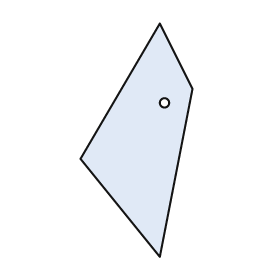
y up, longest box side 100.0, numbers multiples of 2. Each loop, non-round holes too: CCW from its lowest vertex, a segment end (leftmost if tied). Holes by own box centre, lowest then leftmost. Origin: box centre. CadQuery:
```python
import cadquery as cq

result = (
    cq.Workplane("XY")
    .moveTo(10.0, -50.0)
    .lineTo(24.0, 22.0)
    .lineTo(10.0, 50.0)
    .lineTo(-24.0, -8.0)
    .close()
    .moveTo(12.0, 16.0)
    .circle(2.0)
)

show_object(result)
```